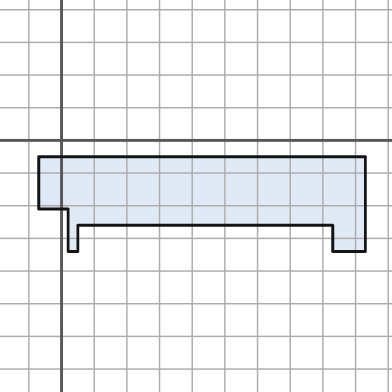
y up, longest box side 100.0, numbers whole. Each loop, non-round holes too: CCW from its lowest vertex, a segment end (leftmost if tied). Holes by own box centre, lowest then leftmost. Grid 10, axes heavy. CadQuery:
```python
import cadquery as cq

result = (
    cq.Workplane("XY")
    .moveTo(2.0, -34.0)
    .lineTo(5.0, -34.0)
    .lineTo(5.0, -26.0)
    .lineTo(83.0, -26.0)
    .lineTo(83.0, -34.0)
    .lineTo(93.0, -34.0)
    .lineTo(93.0, -5.0)
    .lineTo(-7.0, -5.0)
    .lineTo(-7.0, -21.0)
    .lineTo(2.0, -21.0)
    .close()
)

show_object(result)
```